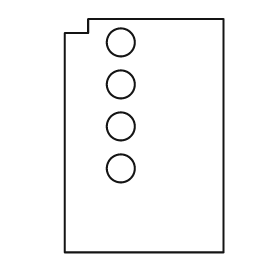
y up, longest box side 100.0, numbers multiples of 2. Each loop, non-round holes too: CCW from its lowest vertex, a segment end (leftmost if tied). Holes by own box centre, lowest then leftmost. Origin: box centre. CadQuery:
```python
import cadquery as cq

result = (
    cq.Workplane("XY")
    .moveTo(-34.0, -50.0)
    .lineTo(34.0, -50.0)
    .lineTo(34.0, 50.0)
    .lineTo(-24.0, 50.0)
    .lineTo(-24.0, 44.0)
    .lineTo(-34.0, 44.0)
    .close()
    .moveTo(-10.0, -14.0)
    .circle(6.0)
    .moveTo(-10.0, 4.0)
    .circle(6.0)
    .moveTo(-10.0, 22.0)
    .circle(6.0)
    .moveTo(-10.0, 40.0)
    .circle(6.0)
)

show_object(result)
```